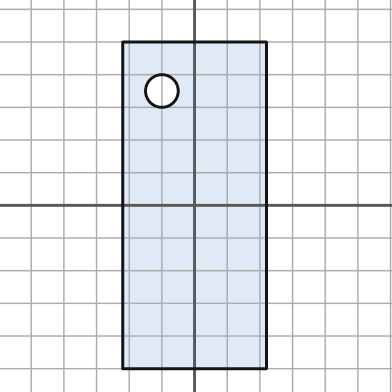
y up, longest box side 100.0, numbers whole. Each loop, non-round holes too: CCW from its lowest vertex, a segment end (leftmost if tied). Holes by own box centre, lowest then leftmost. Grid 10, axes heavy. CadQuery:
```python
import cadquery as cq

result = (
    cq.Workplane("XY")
    .moveTo(-22.0, -50.0)
    .lineTo(22.0, -50.0)
    .lineTo(22.0, 50.0)
    .lineTo(-22.0, 50.0)
    .close()
    .moveTo(-10.0, 35.0)
    .circle(5.0)
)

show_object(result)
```